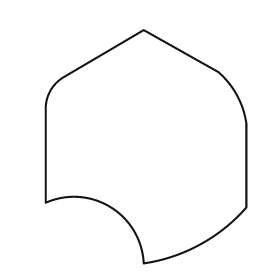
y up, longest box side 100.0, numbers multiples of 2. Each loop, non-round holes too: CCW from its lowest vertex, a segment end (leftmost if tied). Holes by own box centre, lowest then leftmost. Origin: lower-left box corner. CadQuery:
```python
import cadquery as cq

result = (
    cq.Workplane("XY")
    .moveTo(42.0, 0.0)
    .threePointArc((66.0, 8.0), (86.0, 24.0))
    .lineTo(86.0, 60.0)
    .threePointArc((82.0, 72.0), (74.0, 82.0))
    .lineTo(42.0, 100.0)
    .lineTo(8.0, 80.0)
    .threePointArc((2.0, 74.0), (0.0, 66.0))
    .lineTo(0.0, 26.0)
    .threePointArc((28.0, 24.0), (42.0, 0.0))
    .close()
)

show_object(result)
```